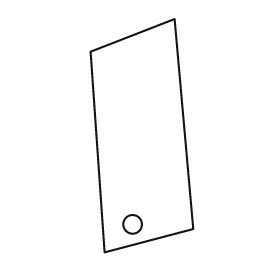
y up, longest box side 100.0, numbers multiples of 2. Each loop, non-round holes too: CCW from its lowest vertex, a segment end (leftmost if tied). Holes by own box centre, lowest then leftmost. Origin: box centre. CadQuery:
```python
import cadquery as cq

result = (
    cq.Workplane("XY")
    .moveTo(-16.0, -50.0)
    .lineTo(22.0, -40.0)
    .lineTo(14.0, 50.0)
    .lineTo(-22.0, 36.0)
    .close()
    .moveTo(-4.0, -38.0)
    .circle(4.0)
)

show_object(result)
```